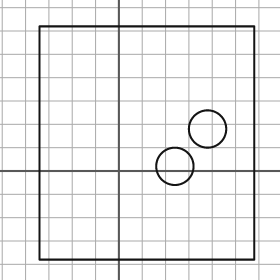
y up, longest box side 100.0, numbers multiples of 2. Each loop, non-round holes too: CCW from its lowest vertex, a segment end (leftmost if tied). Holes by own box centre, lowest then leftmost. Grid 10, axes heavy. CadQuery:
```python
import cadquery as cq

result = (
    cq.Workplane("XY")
    .moveTo(-34.0, -38.0)
    .lineTo(58.0, -38.0)
    .lineTo(58.0, 62.0)
    .lineTo(-34.0, 62.0)
    .close()
    .moveTo(24.0, 2.0)
    .circle(8.0)
    .moveTo(38.0, 18.0)
    .circle(8.0)
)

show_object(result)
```